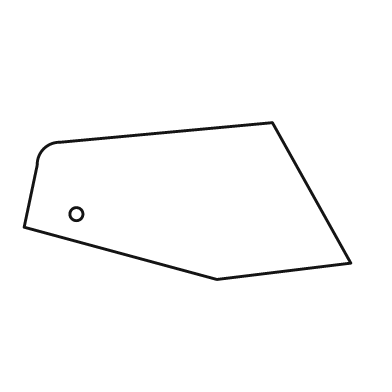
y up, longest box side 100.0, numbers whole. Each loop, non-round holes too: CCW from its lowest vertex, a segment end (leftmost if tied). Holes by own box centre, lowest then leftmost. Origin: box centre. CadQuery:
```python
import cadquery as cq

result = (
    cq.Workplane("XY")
    .moveTo(9.0, -24.0)
    .lineTo(50.0, -19.0)
    .lineTo(26.0, 24.0)
    .lineTo(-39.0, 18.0)
    .threePointArc((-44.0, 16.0), (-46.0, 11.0))
    .lineTo(-50.0, -8.0)
    .close()
    .moveTo(-34.0, -4.0)
    .circle(2.0)
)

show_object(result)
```